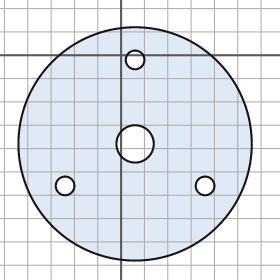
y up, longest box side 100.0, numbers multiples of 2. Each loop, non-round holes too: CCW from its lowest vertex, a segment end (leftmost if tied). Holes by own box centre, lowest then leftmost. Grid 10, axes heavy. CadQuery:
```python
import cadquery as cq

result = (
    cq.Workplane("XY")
    .moveTo(6.0, -38.0)
    .circle(50.0)
    .moveTo(-24.0, -56.0)
    .circle(4.0)
    .moveTo(36.0, -56.0)
    .circle(4.0)
    .moveTo(6.0, -38.0)
    .circle(8.0)
    .moveTo(6.0, -2.0)
    .circle(4.0)
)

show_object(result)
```